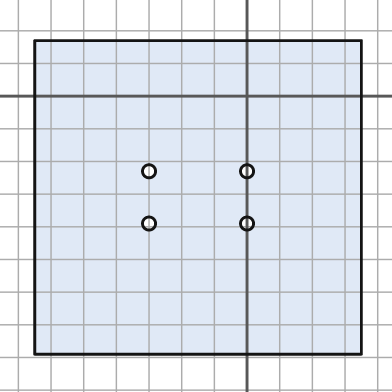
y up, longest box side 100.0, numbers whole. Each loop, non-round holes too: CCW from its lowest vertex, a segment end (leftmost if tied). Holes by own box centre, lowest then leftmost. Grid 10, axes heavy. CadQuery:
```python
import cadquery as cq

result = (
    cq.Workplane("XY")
    .moveTo(-65.0, -79.0)
    .lineTo(35.0, -79.0)
    .lineTo(35.0, 17.0)
    .lineTo(-65.0, 17.0)
    .close()
    .moveTo(-30.0, -39.0)
    .circle(2.0)
    .moveTo(0.0, -39.0)
    .circle(2.0)
    .moveTo(-30.0, -23.0)
    .circle(2.0)
    .moveTo(0.0, -23.0)
    .circle(2.0)
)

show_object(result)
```